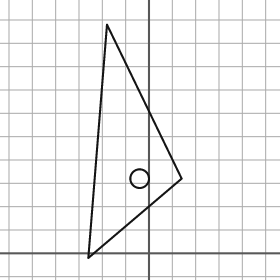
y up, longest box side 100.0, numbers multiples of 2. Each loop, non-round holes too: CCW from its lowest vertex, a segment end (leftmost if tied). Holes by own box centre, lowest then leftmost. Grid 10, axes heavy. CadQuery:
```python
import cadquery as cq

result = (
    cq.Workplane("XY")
    .moveTo(-26.0, -2.0)
    .lineTo(14.0, 32.0)
    .lineTo(-18.0, 98.0)
    .close()
    .moveTo(-4.0, 32.0)
    .circle(4.0)
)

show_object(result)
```